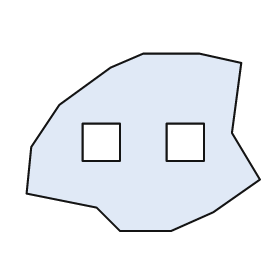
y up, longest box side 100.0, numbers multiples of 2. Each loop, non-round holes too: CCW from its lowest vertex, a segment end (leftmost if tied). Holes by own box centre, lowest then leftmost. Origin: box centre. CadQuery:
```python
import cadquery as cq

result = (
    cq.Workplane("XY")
    .moveTo(-10.0, -38.0)
    .lineTo(12.0, -38.0)
    .lineTo(30.0, -30.0)
    .lineTo(50.0, -16.0)
    .lineTo(38.0, 4.0)
    .lineTo(42.0, 34.0)
    .lineTo(24.0, 38.0)
    .lineTo(0.0, 38.0)
    .lineTo(-14.0, 32.0)
    .lineTo(-36.0, 16.0)
    .lineTo(-48.0, -2.0)
    .lineTo(-50.0, -22.0)
    .lineTo(-20.0, -28.0)
    .close()
    .moveTo(-26.0, -8.0)
    .lineTo(-10.0, -8.0)
    .lineTo(-10.0, 8.0)
    .lineTo(-26.0, 8.0)
    .close()
    .moveTo(10.0, -8.0)
    .lineTo(26.0, -8.0)
    .lineTo(26.0, 8.0)
    .lineTo(10.0, 8.0)
    .close()
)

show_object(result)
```